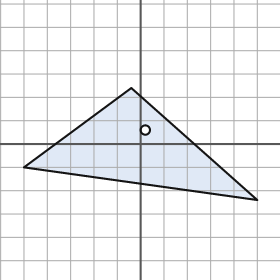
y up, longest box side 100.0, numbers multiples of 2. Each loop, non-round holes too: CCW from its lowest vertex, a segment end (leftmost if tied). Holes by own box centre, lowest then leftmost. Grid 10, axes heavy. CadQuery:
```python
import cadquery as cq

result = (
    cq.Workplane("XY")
    .moveTo(50.0, -24.0)
    .lineTo(-4.0, 24.0)
    .lineTo(-50.0, -10.0)
    .close()
    .moveTo(2.0, 6.0)
    .circle(2.0)
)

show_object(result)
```